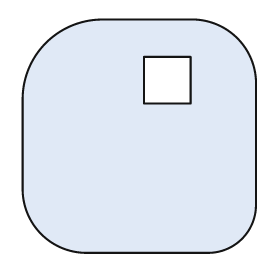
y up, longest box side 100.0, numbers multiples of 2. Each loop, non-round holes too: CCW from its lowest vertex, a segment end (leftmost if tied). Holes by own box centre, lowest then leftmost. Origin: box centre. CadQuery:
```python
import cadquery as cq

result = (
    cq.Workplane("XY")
    .moveTo(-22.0, -50.0)
    .lineTo(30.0, -50.0)
    .threePointArc((44.0, -44.0), (50.0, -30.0))
    .lineTo(50.0, 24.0)
    .threePointArc((42.0, 42.0), (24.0, 50.0))
    .lineTo(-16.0, 50.0)
    .threePointArc((-40.0, 40.0), (-50.0, 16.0))
    .lineTo(-50.0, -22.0)
    .threePointArc((-42.0, -42.0), (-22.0, -50.0))
    .close()
    .moveTo(2.0, 14.0)
    .lineTo(22.0, 14.0)
    .lineTo(22.0, 34.0)
    .lineTo(2.0, 34.0)
    .close()
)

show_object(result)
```